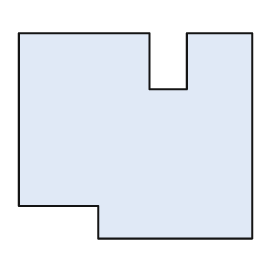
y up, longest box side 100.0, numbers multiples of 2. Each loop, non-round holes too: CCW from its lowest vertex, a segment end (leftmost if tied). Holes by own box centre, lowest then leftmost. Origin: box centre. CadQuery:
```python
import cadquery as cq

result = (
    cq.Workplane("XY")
    .moveTo(-16.0, -44.0)
    .lineTo(50.0, -44.0)
    .lineTo(50.0, 44.0)
    .lineTo(22.0, 44.0)
    .lineTo(22.0, 20.0)
    .lineTo(6.0, 20.0)
    .lineTo(6.0, 44.0)
    .lineTo(-50.0, 44.0)
    .lineTo(-50.0, -30.0)
    .lineTo(-16.0, -30.0)
    .close()
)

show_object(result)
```